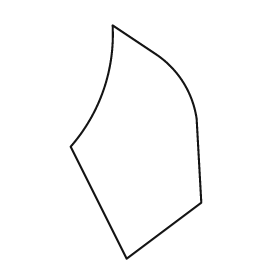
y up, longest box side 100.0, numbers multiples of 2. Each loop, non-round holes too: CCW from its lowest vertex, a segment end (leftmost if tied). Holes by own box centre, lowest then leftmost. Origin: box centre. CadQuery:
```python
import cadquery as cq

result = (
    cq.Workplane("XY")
    .moveTo(-4.0, -50.0)
    .lineTo(28.0, -26.0)
    .lineTo(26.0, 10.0)
    .threePointArc((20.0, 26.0), (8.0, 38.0))
    .lineTo(-10.0, 50.0)
    .threePointArc((-14.0, 22.0), (-28.0, -2.0))
    .close()
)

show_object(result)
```